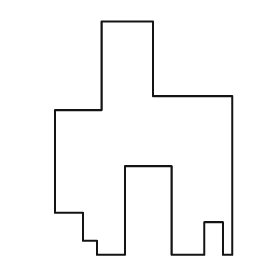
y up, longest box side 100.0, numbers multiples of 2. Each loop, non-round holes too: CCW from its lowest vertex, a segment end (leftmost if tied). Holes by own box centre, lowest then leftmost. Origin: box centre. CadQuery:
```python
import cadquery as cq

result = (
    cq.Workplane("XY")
    .moveTo(-20.0, -50.0)
    .lineTo(-8.0, -50.0)
    .lineTo(-8.0, -12.0)
    .lineTo(12.0, -12.0)
    .lineTo(12.0, -50.0)
    .lineTo(26.0, -50.0)
    .lineTo(26.0, -36.0)
    .lineTo(34.0, -36.0)
    .lineTo(34.0, -50.0)
    .lineTo(38.0, -50.0)
    .lineTo(38.0, 18.0)
    .lineTo(4.0, 18.0)
    .lineTo(4.0, 50.0)
    .lineTo(-18.0, 50.0)
    .lineTo(-18.0, 12.0)
    .lineTo(-38.0, 12.0)
    .lineTo(-38.0, -32.0)
    .lineTo(-26.0, -32.0)
    .lineTo(-26.0, -44.0)
    .lineTo(-20.0, -44.0)
    .close()
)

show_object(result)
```